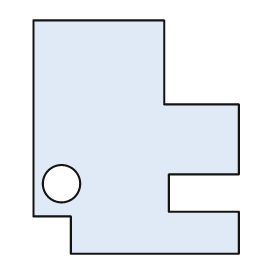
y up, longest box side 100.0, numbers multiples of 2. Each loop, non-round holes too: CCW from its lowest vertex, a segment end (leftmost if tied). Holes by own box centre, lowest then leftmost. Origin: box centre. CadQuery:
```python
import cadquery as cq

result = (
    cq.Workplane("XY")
    .moveTo(-28.0, -50.0)
    .lineTo(44.0, -50.0)
    .lineTo(44.0, -32.0)
    .lineTo(14.0, -32.0)
    .lineTo(14.0, -16.0)
    .lineTo(44.0, -16.0)
    .lineTo(44.0, 14.0)
    .lineTo(12.0, 14.0)
    .lineTo(12.0, 50.0)
    .lineTo(-44.0, 50.0)
    .lineTo(-44.0, -34.0)
    .lineTo(-28.0, -34.0)
    .close()
    .moveTo(-32.0, -20.0)
    .circle(8.0)
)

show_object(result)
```